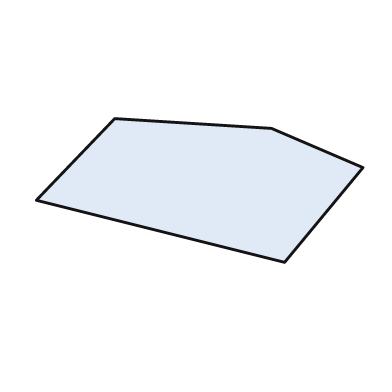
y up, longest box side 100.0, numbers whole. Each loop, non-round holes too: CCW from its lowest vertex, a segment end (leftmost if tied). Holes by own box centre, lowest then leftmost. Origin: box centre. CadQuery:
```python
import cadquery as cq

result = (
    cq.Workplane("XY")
    .moveTo(26.0, -22.0)
    .lineTo(50.0, 7.0)
    .lineTo(22.0, 19.0)
    .lineTo(-26.0, 22.0)
    .lineTo(-50.0, -3.0)
    .close()
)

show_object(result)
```